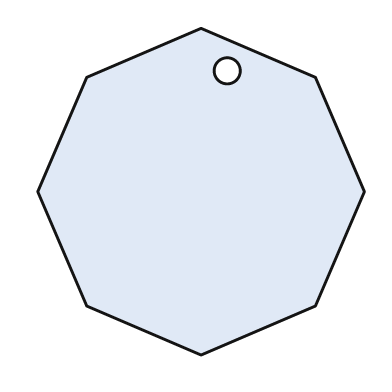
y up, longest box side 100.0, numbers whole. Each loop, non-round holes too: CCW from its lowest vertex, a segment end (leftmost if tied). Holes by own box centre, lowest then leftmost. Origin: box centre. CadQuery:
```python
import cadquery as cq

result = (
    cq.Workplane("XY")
    .moveTo(0.0, -50.0)
    .lineTo(35.0, -35.0)
    .lineTo(50.0, 0.0)
    .lineTo(35.0, 35.0)
    .lineTo(0.0, 50.0)
    .lineTo(-35.0, 35.0)
    .lineTo(-50.0, 0.0)
    .lineTo(-35.0, -35.0)
    .close()
    .moveTo(8.0, 37.0)
    .circle(4.0)
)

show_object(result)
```